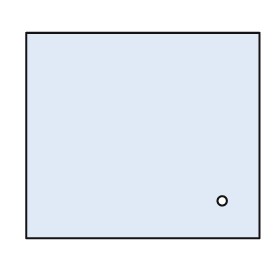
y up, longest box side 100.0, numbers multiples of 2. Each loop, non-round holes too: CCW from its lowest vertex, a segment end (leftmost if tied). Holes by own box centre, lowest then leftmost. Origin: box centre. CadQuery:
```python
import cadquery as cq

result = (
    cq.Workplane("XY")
    .moveTo(-50.0, -44.0)
    .lineTo(50.0, -44.0)
    .lineTo(50.0, 44.0)
    .lineTo(-50.0, 44.0)
    .close()
    .moveTo(34.0, -28.0)
    .circle(2.0)
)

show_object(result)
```